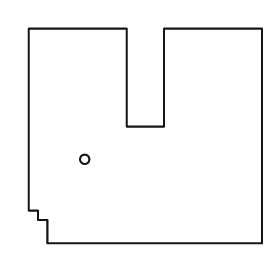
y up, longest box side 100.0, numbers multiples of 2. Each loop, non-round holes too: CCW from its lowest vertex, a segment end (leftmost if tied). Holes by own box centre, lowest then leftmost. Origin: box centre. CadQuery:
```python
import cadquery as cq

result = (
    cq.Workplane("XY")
    .moveTo(-42.0, -46.0)
    .lineTo(50.0, -46.0)
    .lineTo(50.0, 46.0)
    .lineTo(8.0, 46.0)
    .lineTo(8.0, 4.0)
    .lineTo(-8.0, 4.0)
    .lineTo(-8.0, 46.0)
    .lineTo(-50.0, 46.0)
    .lineTo(-50.0, -32.0)
    .lineTo(-46.0, -32.0)
    .lineTo(-46.0, -36.0)
    .lineTo(-42.0, -36.0)
    .close()
    .moveTo(-26.0, -10.0)
    .circle(2.0)
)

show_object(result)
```